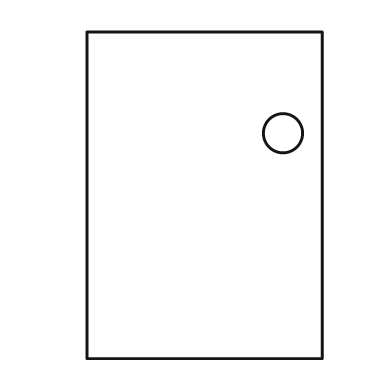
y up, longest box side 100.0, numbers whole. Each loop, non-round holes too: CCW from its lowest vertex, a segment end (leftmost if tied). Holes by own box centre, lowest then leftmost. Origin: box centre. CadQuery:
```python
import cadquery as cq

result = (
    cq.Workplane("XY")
    .moveTo(-36.0, -50.0)
    .lineTo(36.0, -50.0)
    .lineTo(36.0, 50.0)
    .lineTo(-36.0, 50.0)
    .close()
    .moveTo(24.0, 19.0)
    .circle(6.0)
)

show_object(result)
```